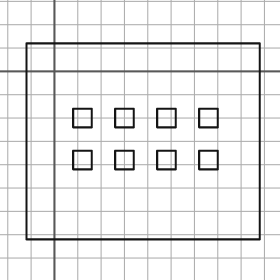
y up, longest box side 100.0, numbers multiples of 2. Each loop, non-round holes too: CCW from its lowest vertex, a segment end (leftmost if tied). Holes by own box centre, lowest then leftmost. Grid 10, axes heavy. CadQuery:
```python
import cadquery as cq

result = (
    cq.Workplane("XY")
    .moveTo(-12.0, -72.0)
    .lineTo(88.0, -72.0)
    .lineTo(88.0, 12.0)
    .lineTo(-12.0, 12.0)
    .close()
    .moveTo(8.0, -42.0)
    .lineTo(16.0, -42.0)
    .lineTo(16.0, -34.0)
    .lineTo(8.0, -34.0)
    .close()
    .moveTo(26.0, -42.0)
    .lineTo(34.0, -42.0)
    .lineTo(34.0, -34.0)
    .lineTo(26.0, -34.0)
    .close()
    .moveTo(44.0, -42.0)
    .lineTo(52.0, -42.0)
    .lineTo(52.0, -34.0)
    .lineTo(44.0, -34.0)
    .close()
    .moveTo(62.0, -42.0)
    .lineTo(70.0, -42.0)
    .lineTo(70.0, -34.0)
    .lineTo(62.0, -34.0)
    .close()
    .moveTo(8.0, -24.0)
    .lineTo(16.0, -24.0)
    .lineTo(16.0, -16.0)
    .lineTo(8.0, -16.0)
    .close()
    .moveTo(26.0, -24.0)
    .lineTo(34.0, -24.0)
    .lineTo(34.0, -16.0)
    .lineTo(26.0, -16.0)
    .close()
    .moveTo(44.0, -24.0)
    .lineTo(52.0, -24.0)
    .lineTo(52.0, -16.0)
    .lineTo(44.0, -16.0)
    .close()
    .moveTo(62.0, -24.0)
    .lineTo(70.0, -24.0)
    .lineTo(70.0, -16.0)
    .lineTo(62.0, -16.0)
    .close()
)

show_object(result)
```